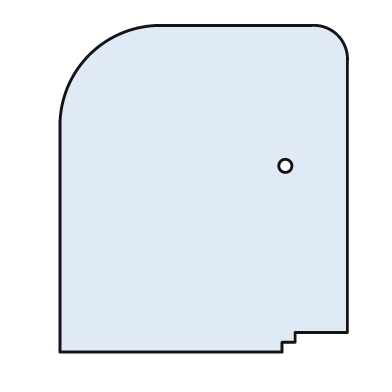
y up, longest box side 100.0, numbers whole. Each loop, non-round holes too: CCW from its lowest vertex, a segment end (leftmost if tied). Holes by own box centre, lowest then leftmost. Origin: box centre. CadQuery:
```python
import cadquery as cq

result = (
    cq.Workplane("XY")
    .moveTo(-44.0, -50.0)
    .lineTo(24.0, -50.0)
    .lineTo(24.0, -47.0)
    .lineTo(28.0, -47.0)
    .lineTo(28.0, -44.0)
    .lineTo(44.0, -44.0)
    .lineTo(44.0, 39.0)
    .threePointArc((41.0, 47.0), (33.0, 50.0))
    .lineTo(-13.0, 50.0)
    .threePointArc((-35.0, 41.0), (-44.0, 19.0))
    .close()
    .moveTo(25.0, 7.0)
    .circle(2.0)
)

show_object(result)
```